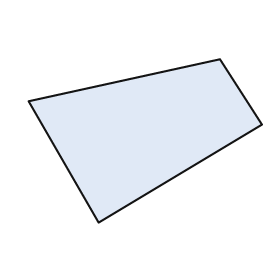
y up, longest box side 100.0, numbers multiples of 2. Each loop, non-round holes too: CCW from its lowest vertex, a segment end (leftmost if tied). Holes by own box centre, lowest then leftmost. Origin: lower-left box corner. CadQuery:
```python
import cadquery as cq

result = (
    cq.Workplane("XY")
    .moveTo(30.0, 0.0)
    .lineTo(100.0, 42.0)
    .lineTo(82.0, 70.0)
    .lineTo(0.0, 52.0)
    .close()
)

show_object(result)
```